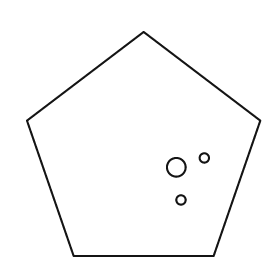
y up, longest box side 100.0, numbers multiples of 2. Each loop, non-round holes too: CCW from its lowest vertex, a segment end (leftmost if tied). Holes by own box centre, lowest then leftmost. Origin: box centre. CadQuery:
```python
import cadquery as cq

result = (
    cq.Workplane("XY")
    .moveTo(-30.0, -48.0)
    .lineTo(30.0, -48.0)
    .lineTo(50.0, 10.0)
    .lineTo(0.0, 48.0)
    .lineTo(-50.0, 10.0)
    .close()
    .moveTo(16.0, -24.0)
    .circle(2.0)
    .moveTo(14.0, -10.0)
    .circle(4.0)
    .moveTo(26.0, -6.0)
    .circle(2.0)
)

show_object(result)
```